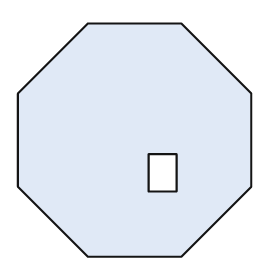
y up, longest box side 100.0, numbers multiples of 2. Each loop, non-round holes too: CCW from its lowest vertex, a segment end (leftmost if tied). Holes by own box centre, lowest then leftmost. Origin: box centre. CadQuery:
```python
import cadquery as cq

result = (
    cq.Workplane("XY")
    .moveTo(-20.0, -50.0)
    .lineTo(20.0, -50.0)
    .lineTo(50.0, -20.0)
    .lineTo(50.0, 20.0)
    .lineTo(20.0, 50.0)
    .lineTo(-20.0, 50.0)
    .lineTo(-50.0, 20.0)
    .lineTo(-50.0, -20.0)
    .close()
    .moveTo(6.0, -22.0)
    .lineTo(18.0, -22.0)
    .lineTo(18.0, -6.0)
    .lineTo(6.0, -6.0)
    .close()
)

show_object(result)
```